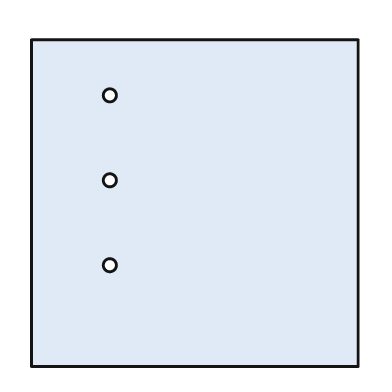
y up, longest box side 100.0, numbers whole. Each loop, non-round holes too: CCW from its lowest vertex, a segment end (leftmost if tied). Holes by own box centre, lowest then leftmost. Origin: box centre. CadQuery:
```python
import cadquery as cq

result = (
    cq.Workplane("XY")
    .moveTo(-50.0, -50.0)
    .lineTo(50.0, -50.0)
    .lineTo(50.0, 50.0)
    .lineTo(-50.0, 50.0)
    .close()
    .moveTo(-26.0, -19.0)
    .circle(2.0)
    .moveTo(-26.0, 7.0)
    .circle(2.0)
    .moveTo(-26.0, 33.0)
    .circle(2.0)
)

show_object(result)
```